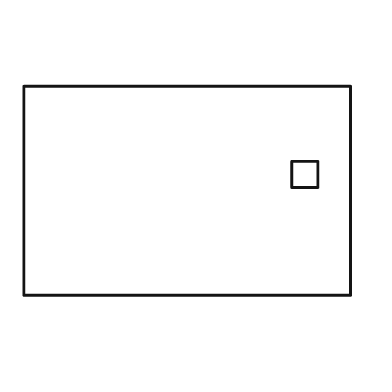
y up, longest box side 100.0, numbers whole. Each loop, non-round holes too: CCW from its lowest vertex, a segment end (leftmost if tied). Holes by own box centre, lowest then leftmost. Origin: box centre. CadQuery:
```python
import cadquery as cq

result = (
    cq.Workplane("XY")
    .moveTo(-50.0, -32.0)
    .lineTo(50.0, -32.0)
    .lineTo(50.0, 32.0)
    .lineTo(-50.0, 32.0)
    .close()
    .moveTo(32.0, 1.0)
    .lineTo(40.0, 1.0)
    .lineTo(40.0, 9.0)
    .lineTo(32.0, 9.0)
    .close()
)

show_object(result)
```